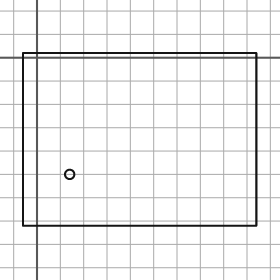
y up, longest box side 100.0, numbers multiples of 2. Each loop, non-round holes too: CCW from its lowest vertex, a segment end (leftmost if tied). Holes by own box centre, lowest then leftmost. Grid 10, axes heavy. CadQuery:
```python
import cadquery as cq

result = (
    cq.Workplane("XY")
    .moveTo(-6.0, -72.0)
    .lineTo(94.0, -72.0)
    .lineTo(94.0, 2.0)
    .lineTo(-6.0, 2.0)
    .close()
    .moveTo(14.0, -50.0)
    .circle(2.0)
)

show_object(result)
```